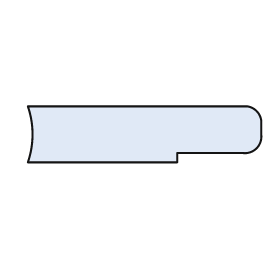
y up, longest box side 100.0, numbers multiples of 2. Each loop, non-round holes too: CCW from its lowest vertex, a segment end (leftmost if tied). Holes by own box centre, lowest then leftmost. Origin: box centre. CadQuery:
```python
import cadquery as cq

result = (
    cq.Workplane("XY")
    .moveTo(-50.0, -12.0)
    .lineTo(14.0, -12.0)
    .lineTo(14.0, -8.0)
    .lineTo(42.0, -8.0)
    .threePointArc((48.0, -6.0), (50.0, 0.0))
    .lineTo(50.0, 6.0)
    .threePointArc((48.0, 10.0), (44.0, 12.0))
    .lineTo(-50.0, 12.0)
    .threePointArc((-48.0, 0.0), (-50.0, -12.0))
    .close()
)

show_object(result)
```